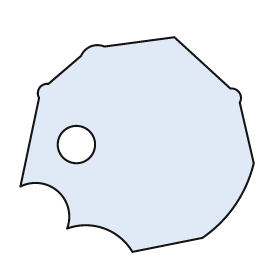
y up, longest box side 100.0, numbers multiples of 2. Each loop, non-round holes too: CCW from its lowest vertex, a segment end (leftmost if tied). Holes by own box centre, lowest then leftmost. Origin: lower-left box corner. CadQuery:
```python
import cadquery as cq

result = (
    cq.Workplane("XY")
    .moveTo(48.0, 0.0)
    .lineTo(78.0, 6.0)
    .threePointArc((92.0, 20.0), (100.0, 38.0))
    .lineTo(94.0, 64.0)
    .threePointArc((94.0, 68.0), (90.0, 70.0))
    .lineTo(66.0, 92.0)
    .lineTo(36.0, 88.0)
    .threePointArc((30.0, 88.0), (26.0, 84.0))
    .lineTo(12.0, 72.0)
    .threePointArc((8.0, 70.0), (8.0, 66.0))
    .lineTo(0.0, 28.0)
    .threePointArc((16.0, 26.0), (20.0, 10.0))
    .threePointArc((36.0, 10.0), (48.0, 0.0))
    .close()
    .moveTo(24.0, 46.0)
    .circle(8.0)
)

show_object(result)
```